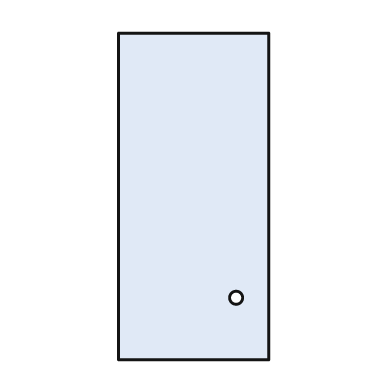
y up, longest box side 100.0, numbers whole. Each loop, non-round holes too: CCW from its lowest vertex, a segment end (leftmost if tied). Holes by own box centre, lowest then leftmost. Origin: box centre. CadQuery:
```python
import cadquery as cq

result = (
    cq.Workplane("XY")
    .moveTo(-23.0, -50.0)
    .lineTo(23.0, -50.0)
    .lineTo(23.0, 50.0)
    .lineTo(-23.0, 50.0)
    .close()
    .moveTo(13.0, -31.0)
    .circle(2.0)
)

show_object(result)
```